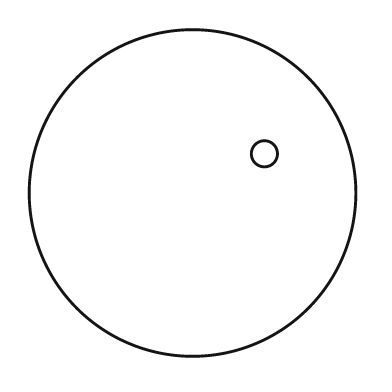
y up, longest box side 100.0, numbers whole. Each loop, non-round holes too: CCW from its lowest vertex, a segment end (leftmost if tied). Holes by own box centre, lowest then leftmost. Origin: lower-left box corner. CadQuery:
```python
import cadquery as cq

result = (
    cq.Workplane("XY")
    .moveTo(50.0, 50.0)
    .circle(50.0)
    .moveTo(72.0, 62.0)
    .circle(4.0)
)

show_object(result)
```